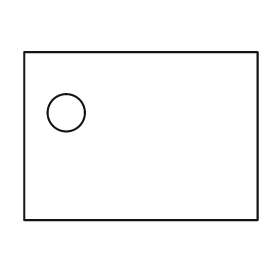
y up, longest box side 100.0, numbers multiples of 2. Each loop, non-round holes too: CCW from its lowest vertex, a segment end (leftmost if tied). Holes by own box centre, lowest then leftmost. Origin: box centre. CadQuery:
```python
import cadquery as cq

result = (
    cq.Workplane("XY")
    .moveTo(-50.0, -36.0)
    .lineTo(50.0, -36.0)
    .lineTo(50.0, 36.0)
    .lineTo(-50.0, 36.0)
    .close()
    .moveTo(-32.0, 10.0)
    .circle(8.0)
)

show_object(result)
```